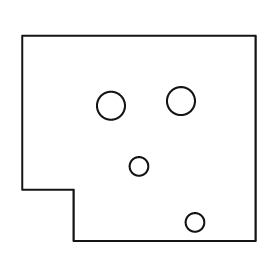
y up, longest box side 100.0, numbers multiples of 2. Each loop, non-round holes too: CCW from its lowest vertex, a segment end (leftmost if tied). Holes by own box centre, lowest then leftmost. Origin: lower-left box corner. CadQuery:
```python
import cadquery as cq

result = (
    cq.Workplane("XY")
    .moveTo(22.0, 0.0)
    .lineTo(100.0, 0.0)
    .lineTo(100.0, 88.0)
    .lineTo(0.0, 88.0)
    .lineTo(0.0, 22.0)
    .lineTo(22.0, 22.0)
    .close()
    .moveTo(74.0, 8.0)
    .circle(4.0)
    .moveTo(50.0, 32.0)
    .circle(4.0)
    .moveTo(38.0, 58.0)
    .circle(6.0)
    .moveTo(68.0, 60.0)
    .circle(6.0)
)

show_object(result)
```